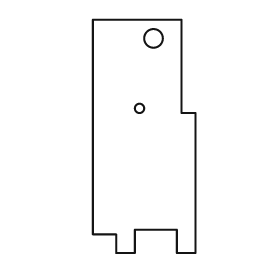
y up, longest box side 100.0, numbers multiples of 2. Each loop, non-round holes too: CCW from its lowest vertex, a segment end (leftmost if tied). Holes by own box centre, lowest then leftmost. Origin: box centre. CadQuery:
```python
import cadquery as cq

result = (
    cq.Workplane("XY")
    .moveTo(-12.0, -50.0)
    .lineTo(-4.0, -50.0)
    .lineTo(-4.0, -40.0)
    .lineTo(14.0, -40.0)
    .lineTo(14.0, -50.0)
    .lineTo(22.0, -50.0)
    .lineTo(22.0, 10.0)
    .lineTo(16.0, 10.0)
    .lineTo(16.0, 50.0)
    .lineTo(-22.0, 50.0)
    .lineTo(-22.0, -42.0)
    .lineTo(-12.0, -42.0)
    .close()
    .moveTo(-2.0, 12.0)
    .circle(2.0)
    .moveTo(4.0, 42.0)
    .circle(4.0)
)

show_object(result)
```